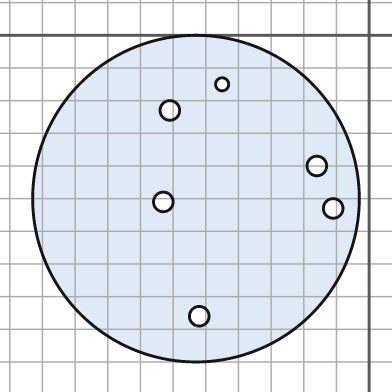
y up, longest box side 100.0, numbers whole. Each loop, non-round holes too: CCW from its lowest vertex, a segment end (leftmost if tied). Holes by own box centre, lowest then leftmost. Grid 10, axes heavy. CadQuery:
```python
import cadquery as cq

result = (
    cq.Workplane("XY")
    .moveTo(-53.0, -50.0)
    .circle(50.0)
    .moveTo(-52.0, -86.0)
    .circle(3.0)
    .moveTo(-11.0, -53.0)
    .circle(3.0)
    .moveTo(-63.0, -51.0)
    .circle(3.0)
    .moveTo(-16.0, -40.0)
    .circle(3.0)
    .moveTo(-61.0, -23.0)
    .circle(3.0)
    .moveTo(-45.0, -15.0)
    .circle(2.0)
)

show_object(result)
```